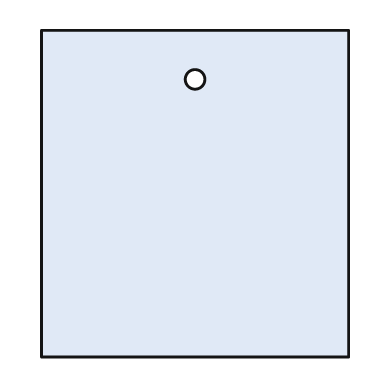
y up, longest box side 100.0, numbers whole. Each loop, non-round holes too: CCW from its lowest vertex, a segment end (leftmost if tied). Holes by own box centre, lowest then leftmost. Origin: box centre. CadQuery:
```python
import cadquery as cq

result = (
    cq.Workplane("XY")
    .moveTo(-47.0, -50.0)
    .lineTo(47.0, -50.0)
    .lineTo(47.0, 50.0)
    .lineTo(-47.0, 50.0)
    .close()
    .moveTo(0.0, 35.0)
    .circle(3.0)
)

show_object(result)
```